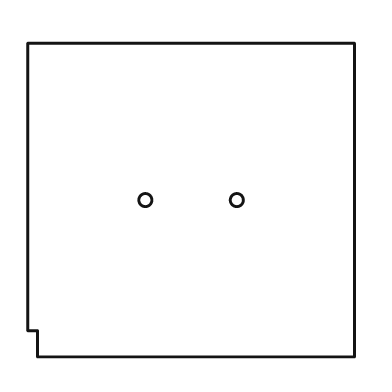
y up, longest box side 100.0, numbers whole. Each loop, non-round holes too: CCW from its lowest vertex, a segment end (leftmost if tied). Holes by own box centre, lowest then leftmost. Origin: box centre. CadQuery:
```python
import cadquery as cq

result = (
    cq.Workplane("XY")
    .moveTo(-47.0, -48.0)
    .lineTo(50.0, -48.0)
    .lineTo(50.0, 48.0)
    .lineTo(-50.0, 48.0)
    .lineTo(-50.0, -40.0)
    .lineTo(-47.0, -40.0)
    .close()
    .moveTo(-14.0, 0.0)
    .circle(2.0)
    .moveTo(14.0, 0.0)
    .circle(2.0)
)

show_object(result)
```